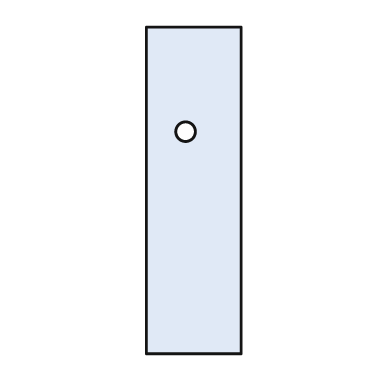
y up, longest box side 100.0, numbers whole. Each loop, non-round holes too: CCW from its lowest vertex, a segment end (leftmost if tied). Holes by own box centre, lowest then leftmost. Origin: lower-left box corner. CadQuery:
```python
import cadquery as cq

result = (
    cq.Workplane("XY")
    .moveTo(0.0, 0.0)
    .lineTo(29.0, 0.0)
    .lineTo(29.0, 100.0)
    .lineTo(0.0, 100.0)
    .close()
    .moveTo(12.0, 68.0)
    .circle(3.0)
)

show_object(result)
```